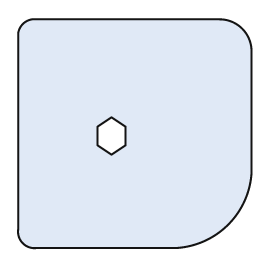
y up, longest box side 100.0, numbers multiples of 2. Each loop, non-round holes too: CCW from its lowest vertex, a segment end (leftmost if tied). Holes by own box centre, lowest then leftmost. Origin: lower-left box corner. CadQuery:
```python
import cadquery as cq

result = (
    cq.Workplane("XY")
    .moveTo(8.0, 0.0)
    .lineTo(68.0, 0.0)
    .threePointArc((90.0, 10.0), (100.0, 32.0))
    .lineTo(100.0, 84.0)
    .threePointArc((96.0, 94.0), (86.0, 98.0))
    .lineTo(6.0, 98.0)
    .threePointArc((2.0, 96.0), (0.0, 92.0))
    .lineTo(0.0, 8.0)
    .threePointArc((2.0, 2.0), (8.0, 0.0))
    .close()
    .moveTo(40.0, 40.0)
    .lineTo(46.0, 44.0)
    .lineTo(46.0, 52.0)
    .lineTo(40.0, 56.0)
    .lineTo(34.0, 52.0)
    .lineTo(34.0, 44.0)
    .close()
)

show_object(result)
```